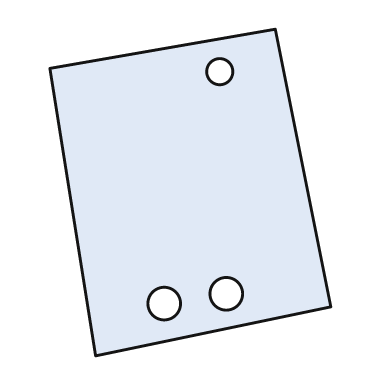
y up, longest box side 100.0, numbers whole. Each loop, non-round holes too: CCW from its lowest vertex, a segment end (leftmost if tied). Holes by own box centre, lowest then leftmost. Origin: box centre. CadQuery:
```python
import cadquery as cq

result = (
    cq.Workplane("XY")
    .moveTo(-29.0, -50.0)
    .lineTo(43.0, -35.0)
    .lineTo(26.0, 50.0)
    .lineTo(-43.0, 38.0)
    .close()
    .moveTo(-8.0, -34.0)
    .circle(5.0)
    .moveTo(11.0, -31.0)
    .circle(5.0)
    .moveTo(9.0, 37.0)
    .circle(4.0)
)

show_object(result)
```